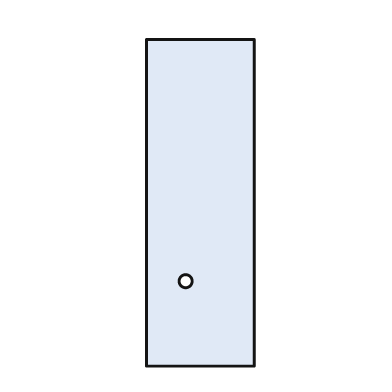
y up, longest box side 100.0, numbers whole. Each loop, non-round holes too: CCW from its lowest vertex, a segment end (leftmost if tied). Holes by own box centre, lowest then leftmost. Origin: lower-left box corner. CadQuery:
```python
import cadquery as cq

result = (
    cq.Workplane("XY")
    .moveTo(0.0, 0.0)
    .lineTo(33.0, 0.0)
    .lineTo(33.0, 100.0)
    .lineTo(0.0, 100.0)
    .close()
    .moveTo(12.0, 26.0)
    .circle(2.0)
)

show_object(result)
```